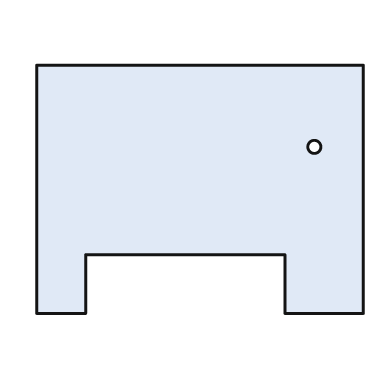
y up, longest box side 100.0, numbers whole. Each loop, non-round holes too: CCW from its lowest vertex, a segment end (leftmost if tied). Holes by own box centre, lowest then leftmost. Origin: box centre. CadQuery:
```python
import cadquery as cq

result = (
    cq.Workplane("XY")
    .moveTo(-50.0, -38.0)
    .lineTo(-35.0, -38.0)
    .lineTo(-35.0, -20.0)
    .lineTo(26.0, -20.0)
    .lineTo(26.0, -38.0)
    .lineTo(50.0, -38.0)
    .lineTo(50.0, 38.0)
    .lineTo(-50.0, 38.0)
    .close()
    .moveTo(35.0, 13.0)
    .circle(2.0)
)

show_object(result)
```